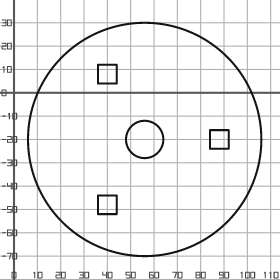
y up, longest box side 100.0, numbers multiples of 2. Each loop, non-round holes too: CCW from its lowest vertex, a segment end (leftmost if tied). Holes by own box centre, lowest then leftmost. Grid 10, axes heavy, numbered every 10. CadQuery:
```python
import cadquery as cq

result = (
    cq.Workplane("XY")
    .moveTo(56.0, -20.0)
    .circle(50.0)
    .moveTo(36.0, -52.0)
    .lineTo(44.0, -52.0)
    .lineTo(44.0, -44.0)
    .lineTo(36.0, -44.0)
    .close()
    .moveTo(56.0, -20.0)
    .circle(8.0)
    .moveTo(84.0, -24.0)
    .lineTo(92.0, -24.0)
    .lineTo(92.0, -16.0)
    .lineTo(84.0, -16.0)
    .close()
    .moveTo(36.0, 4.0)
    .lineTo(44.0, 4.0)
    .lineTo(44.0, 12.0)
    .lineTo(36.0, 12.0)
    .close()
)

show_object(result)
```